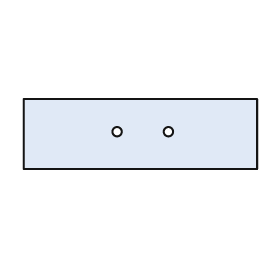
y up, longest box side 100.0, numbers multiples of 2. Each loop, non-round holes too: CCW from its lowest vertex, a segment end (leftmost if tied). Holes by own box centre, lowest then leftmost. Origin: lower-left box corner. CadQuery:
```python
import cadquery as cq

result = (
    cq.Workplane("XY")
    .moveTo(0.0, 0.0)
    .lineTo(100.0, 0.0)
    .lineTo(100.0, 30.0)
    .lineTo(0.0, 30.0)
    .close()
    .moveTo(40.0, 16.0)
    .circle(2.0)
    .moveTo(62.0, 16.0)
    .circle(2.0)
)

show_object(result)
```